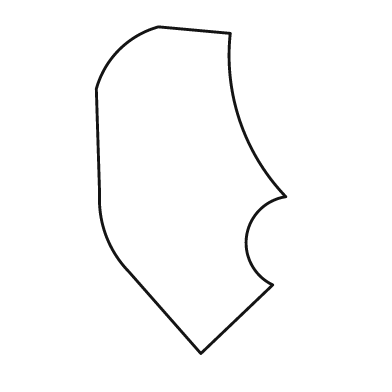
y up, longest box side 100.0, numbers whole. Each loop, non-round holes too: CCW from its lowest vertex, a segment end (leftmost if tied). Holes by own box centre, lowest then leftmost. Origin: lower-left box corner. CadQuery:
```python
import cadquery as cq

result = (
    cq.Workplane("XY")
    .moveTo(32.0, 0.0)
    .lineTo(54.0, 21.0)
    .threePointArc((46.0, 36.0), (58.0, 48.0))
    .threePointArc((44.0, 71.0), (41.0, 98.0))
    .lineTo(19.0, 100.0)
    .threePointArc((7.0, 93.0), (0.0, 81.0))
    .lineTo(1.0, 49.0)
    .threePointArc((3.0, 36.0), (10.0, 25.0))
    .close()
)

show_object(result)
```